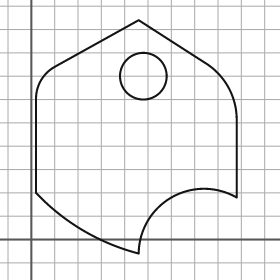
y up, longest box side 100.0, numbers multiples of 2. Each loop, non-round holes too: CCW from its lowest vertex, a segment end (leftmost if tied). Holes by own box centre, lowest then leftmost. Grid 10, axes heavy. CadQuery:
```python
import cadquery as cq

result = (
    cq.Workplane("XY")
    .moveTo(46.0, -6.0)
    .threePointArc((60.0, 18.0), (88.0, 18.0))
    .lineTo(88.0, 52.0)
    .threePointArc((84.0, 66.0), (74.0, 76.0))
    .lineTo(46.0, 94.0)
    .lineTo(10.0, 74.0)
    .threePointArc((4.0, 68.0), (2.0, 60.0))
    .lineTo(2.0, 20.0)
    .threePointArc((22.0, 4.0), (46.0, -6.0))
    .close()
    .moveTo(48.0, 70.0)
    .circle(10.0)
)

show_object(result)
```